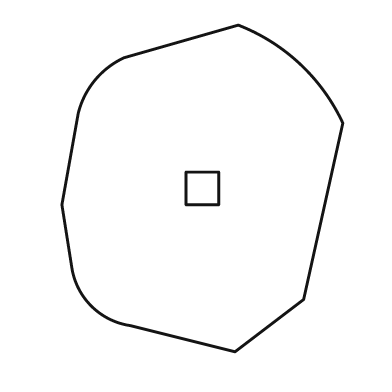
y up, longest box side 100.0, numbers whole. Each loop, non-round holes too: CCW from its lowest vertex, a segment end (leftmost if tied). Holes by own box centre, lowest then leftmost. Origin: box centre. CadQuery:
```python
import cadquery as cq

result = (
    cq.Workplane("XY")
    .moveTo(10.0, -50.0)
    .lineTo(31.0, -34.0)
    .lineTo(43.0, 20.0)
    .threePointArc((30.0, 38.0), (11.0, 50.0))
    .lineTo(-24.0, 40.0)
    .threePointArc((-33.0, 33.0), (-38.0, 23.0))
    .lineTo(-43.0, -5.0)
    .lineTo(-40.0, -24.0)
    .threePointArc((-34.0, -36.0), (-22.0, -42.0))
    .close()
    .moveTo(-5.0, -5.0)
    .lineTo(5.0, -5.0)
    .lineTo(5.0, 5.0)
    .lineTo(-5.0, 5.0)
    .close()
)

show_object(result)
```